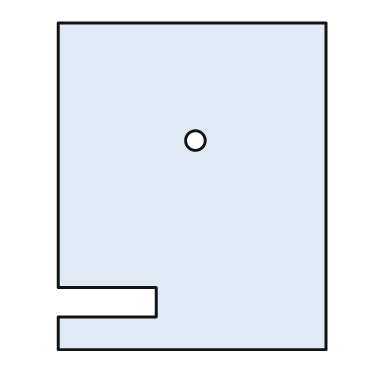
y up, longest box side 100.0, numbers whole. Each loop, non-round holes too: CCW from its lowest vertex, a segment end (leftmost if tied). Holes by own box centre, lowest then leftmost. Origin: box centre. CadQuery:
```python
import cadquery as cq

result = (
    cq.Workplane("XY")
    .moveTo(-41.0, -50.0)
    .lineTo(41.0, -50.0)
    .lineTo(41.0, 50.0)
    .lineTo(-41.0, 50.0)
    .lineTo(-41.0, -31.0)
    .lineTo(-11.0, -31.0)
    .lineTo(-11.0, -40.0)
    .lineTo(-41.0, -40.0)
    .close()
    .moveTo(1.0, 14.0)
    .circle(3.0)
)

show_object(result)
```